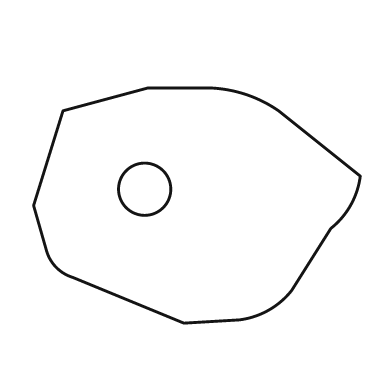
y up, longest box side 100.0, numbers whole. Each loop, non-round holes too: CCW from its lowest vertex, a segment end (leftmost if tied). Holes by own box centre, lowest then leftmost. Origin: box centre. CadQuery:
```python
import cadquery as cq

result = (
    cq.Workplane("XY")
    .moveTo(-4.0, -36.0)
    .lineTo(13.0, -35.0)
    .threePointArc((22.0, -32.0), (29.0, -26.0))
    .lineTo(41.0, -7.0)
    .threePointArc((47.0, 0.0), (50.0, 9.0))
    .lineTo(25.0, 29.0)
    .threePointArc((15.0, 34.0), (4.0, 36.0))
    .lineTo(-15.0, 36.0)
    .lineTo(-41.0, 29.0)
    .lineTo(-50.0, 0.0)
    .lineTo(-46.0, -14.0)
    .threePointArc((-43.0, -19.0), (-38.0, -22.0))
    .close()
    .moveTo(-16.0, 5.0)
    .circle(8.0)
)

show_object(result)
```